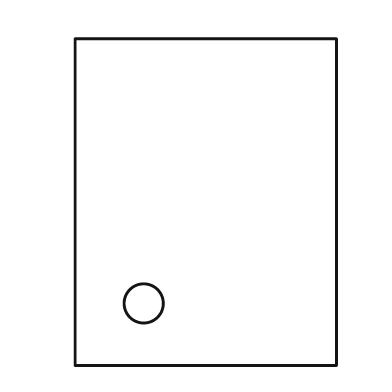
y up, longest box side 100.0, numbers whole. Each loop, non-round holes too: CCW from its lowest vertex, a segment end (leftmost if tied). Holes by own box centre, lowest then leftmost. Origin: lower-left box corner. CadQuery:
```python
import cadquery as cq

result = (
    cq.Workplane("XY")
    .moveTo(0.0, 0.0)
    .lineTo(80.0, 0.0)
    .lineTo(80.0, 100.0)
    .lineTo(0.0, 100.0)
    .close()
    .moveTo(21.0, 19.0)
    .circle(6.0)
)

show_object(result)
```